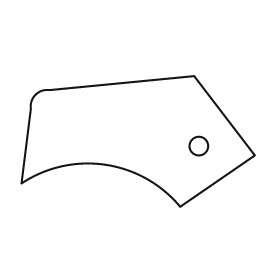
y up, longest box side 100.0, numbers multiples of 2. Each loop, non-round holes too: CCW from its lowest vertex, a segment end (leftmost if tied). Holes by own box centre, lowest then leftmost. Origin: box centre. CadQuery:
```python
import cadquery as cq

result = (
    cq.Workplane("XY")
    .moveTo(18.0, -28.0)
    .lineTo(50.0, -6.0)
    .lineTo(24.0, 28.0)
    .lineTo(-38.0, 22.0)
    .threePointArc((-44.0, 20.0), (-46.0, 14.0))
    .lineTo(-50.0, -18.0)
    .threePointArc((-14.0, -10.0), (18.0, -28.0))
    .close()
    .moveTo(26.0, -2.0)
    .circle(4.0)
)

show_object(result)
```